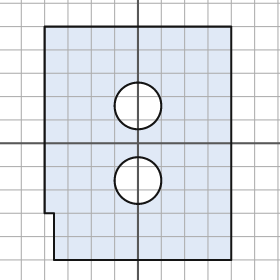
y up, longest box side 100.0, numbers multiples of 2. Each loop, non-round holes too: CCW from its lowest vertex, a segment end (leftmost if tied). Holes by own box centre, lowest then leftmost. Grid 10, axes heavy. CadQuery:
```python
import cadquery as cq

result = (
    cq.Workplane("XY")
    .moveTo(-36.0, -50.0)
    .lineTo(40.0, -50.0)
    .lineTo(40.0, 50.0)
    .lineTo(-40.0, 50.0)
    .lineTo(-40.0, -30.0)
    .lineTo(-36.0, -30.0)
    .close()
    .moveTo(0.0, -16.0)
    .circle(10.0)
    .moveTo(0.0, 16.0)
    .circle(10.0)
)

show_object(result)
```